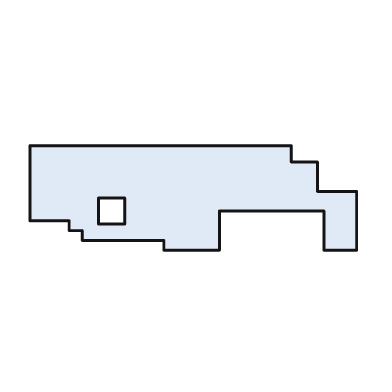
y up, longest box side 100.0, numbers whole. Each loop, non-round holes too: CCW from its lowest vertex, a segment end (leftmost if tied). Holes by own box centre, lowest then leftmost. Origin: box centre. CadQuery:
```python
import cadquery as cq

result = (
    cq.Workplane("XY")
    .moveTo(-9.0, -16.0)
    .lineTo(8.0, -16.0)
    .lineTo(8.0, -4.0)
    .lineTo(40.0, -4.0)
    .lineTo(40.0, -16.0)
    .lineTo(50.0, -16.0)
    .lineTo(50.0, 2.0)
    .lineTo(38.0, 2.0)
    .lineTo(38.0, 11.0)
    .lineTo(30.0, 11.0)
    .lineTo(30.0, 16.0)
    .lineTo(-50.0, 16.0)
    .lineTo(-50.0, -7.0)
    .lineTo(-38.0, -7.0)
    .lineTo(-38.0, -10.0)
    .lineTo(-34.0, -10.0)
    .lineTo(-34.0, -13.0)
    .lineTo(-9.0, -13.0)
    .close()
    .moveTo(-29.0, -8.0)
    .lineTo(-21.0, -8.0)
    .lineTo(-21.0, 0.0)
    .lineTo(-29.0, 0.0)
    .close()
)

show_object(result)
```